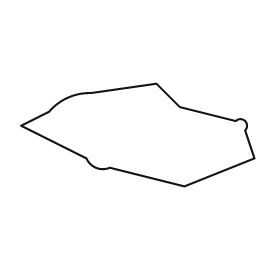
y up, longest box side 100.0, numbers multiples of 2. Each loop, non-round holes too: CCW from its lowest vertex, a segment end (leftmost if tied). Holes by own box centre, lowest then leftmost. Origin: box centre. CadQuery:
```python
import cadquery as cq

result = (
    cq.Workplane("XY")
    .moveTo(20.0, -22.0)
    .lineTo(50.0, -10.0)
    .lineTo(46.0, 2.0)
    .threePointArc((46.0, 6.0), (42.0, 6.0))
    .lineTo(18.0, 12.0)
    .lineTo(8.0, 22.0)
    .lineTo(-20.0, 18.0)
    .threePointArc((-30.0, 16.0), (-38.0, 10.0))
    .lineTo(-50.0, 4.0)
    .lineTo(-22.0, -10.0)
    .threePointArc((-18.0, -14.0), (-12.0, -14.0))
    .close()
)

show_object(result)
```